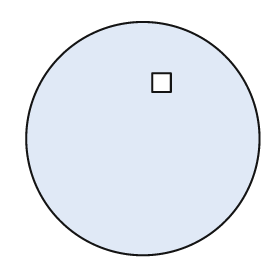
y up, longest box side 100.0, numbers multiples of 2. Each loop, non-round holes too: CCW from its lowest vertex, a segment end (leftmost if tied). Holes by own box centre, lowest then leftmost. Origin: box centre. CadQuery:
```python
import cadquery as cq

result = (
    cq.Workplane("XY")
    .moveTo(0.0, 0.0)
    .circle(50.0)
    .moveTo(4.0, 20.0)
    .lineTo(12.0, 20.0)
    .lineTo(12.0, 28.0)
    .lineTo(4.0, 28.0)
    .close()
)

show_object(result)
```